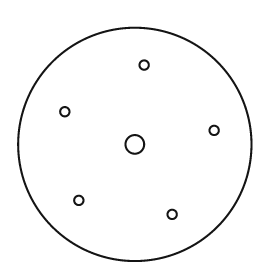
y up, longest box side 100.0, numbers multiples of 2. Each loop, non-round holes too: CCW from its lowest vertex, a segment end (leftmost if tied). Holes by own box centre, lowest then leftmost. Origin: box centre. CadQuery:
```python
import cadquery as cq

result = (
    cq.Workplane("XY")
    .moveTo(0.0, 0.0)
    .circle(50.0)
    .moveTo(16.0, -30.0)
    .circle(2.0)
    .moveTo(-24.0, -24.0)
    .circle(2.0)
    .moveTo(0.0, 0.0)
    .circle(4.0)
    .moveTo(34.0, 6.0)
    .circle(2.0)
    .moveTo(-30.0, 14.0)
    .circle(2.0)
    .moveTo(4.0, 34.0)
    .circle(2.0)
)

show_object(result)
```